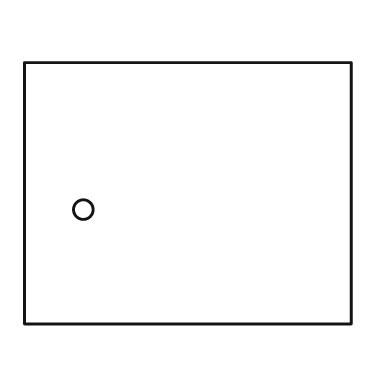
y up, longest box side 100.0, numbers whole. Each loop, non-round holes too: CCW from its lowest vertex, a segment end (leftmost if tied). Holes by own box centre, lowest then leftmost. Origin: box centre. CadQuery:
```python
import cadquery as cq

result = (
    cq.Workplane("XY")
    .moveTo(-50.0, -40.0)
    .lineTo(50.0, -40.0)
    .lineTo(50.0, 40.0)
    .lineTo(-50.0, 40.0)
    .close()
    .moveTo(-32.0, -5.0)
    .circle(3.0)
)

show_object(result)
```